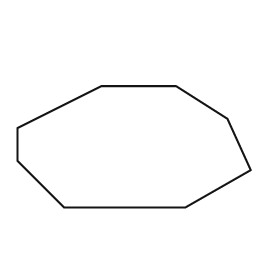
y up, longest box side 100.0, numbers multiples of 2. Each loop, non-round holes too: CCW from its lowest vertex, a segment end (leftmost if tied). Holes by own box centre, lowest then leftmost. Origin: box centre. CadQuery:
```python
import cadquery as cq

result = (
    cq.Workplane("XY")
    .moveTo(-30.0, -26.0)
    .lineTo(22.0, -26.0)
    .lineTo(50.0, -10.0)
    .lineTo(40.0, 12.0)
    .lineTo(18.0, 26.0)
    .lineTo(-14.0, 26.0)
    .lineTo(-50.0, 8.0)
    .lineTo(-50.0, -6.0)
    .close()
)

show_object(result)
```